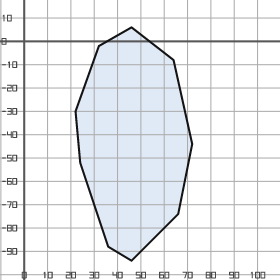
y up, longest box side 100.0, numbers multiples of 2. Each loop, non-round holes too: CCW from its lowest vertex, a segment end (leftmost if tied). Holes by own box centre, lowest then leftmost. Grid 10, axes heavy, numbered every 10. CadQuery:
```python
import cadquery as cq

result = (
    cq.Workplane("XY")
    .moveTo(46.0, -94.0)
    .lineTo(66.0, -74.0)
    .lineTo(72.0, -44.0)
    .lineTo(64.0, -8.0)
    .lineTo(46.0, 6.0)
    .lineTo(32.0, -2.0)
    .lineTo(22.0, -30.0)
    .lineTo(24.0, -52.0)
    .lineTo(36.0, -88.0)
    .close()
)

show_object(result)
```